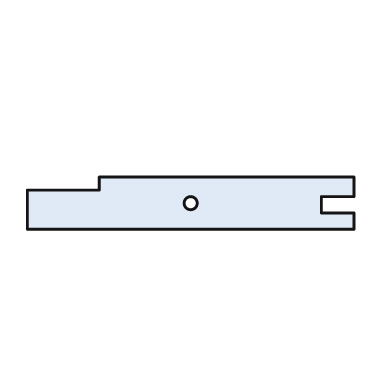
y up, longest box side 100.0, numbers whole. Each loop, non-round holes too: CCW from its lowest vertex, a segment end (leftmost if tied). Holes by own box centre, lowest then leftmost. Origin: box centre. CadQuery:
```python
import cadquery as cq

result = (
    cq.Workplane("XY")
    .moveTo(-50.0, -8.0)
    .lineTo(50.0, -8.0)
    .lineTo(50.0, -3.0)
    .lineTo(40.0, -3.0)
    .lineTo(40.0, 2.0)
    .lineTo(50.0, 2.0)
    .lineTo(50.0, 8.0)
    .lineTo(-28.0, 8.0)
    .lineTo(-28.0, 4.0)
    .lineTo(-50.0, 4.0)
    .close()
    .moveTo(0.0, 0.0)
    .circle(2.0)
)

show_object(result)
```